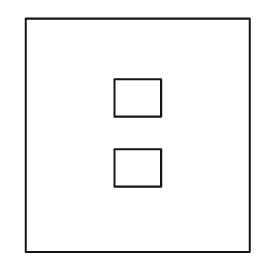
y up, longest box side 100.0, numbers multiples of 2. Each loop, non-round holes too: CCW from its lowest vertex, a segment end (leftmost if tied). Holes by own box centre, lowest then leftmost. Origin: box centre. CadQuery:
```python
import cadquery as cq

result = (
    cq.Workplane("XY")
    .moveTo(-48.0, -50.0)
    .lineTo(48.0, -50.0)
    .lineTo(48.0, 50.0)
    .lineTo(-48.0, 50.0)
    .close()
    .moveTo(-10.0, -22.0)
    .lineTo(10.0, -22.0)
    .lineTo(10.0, -6.0)
    .lineTo(-10.0, -6.0)
    .close()
    .moveTo(-10.0, 8.0)
    .lineTo(10.0, 8.0)
    .lineTo(10.0, 24.0)
    .lineTo(-10.0, 24.0)
    .close()
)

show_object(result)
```